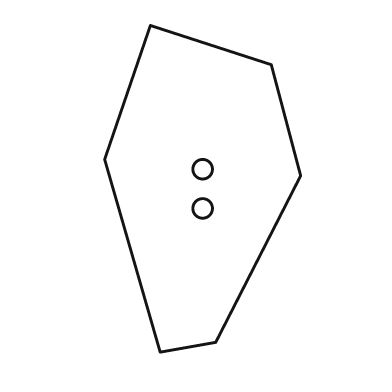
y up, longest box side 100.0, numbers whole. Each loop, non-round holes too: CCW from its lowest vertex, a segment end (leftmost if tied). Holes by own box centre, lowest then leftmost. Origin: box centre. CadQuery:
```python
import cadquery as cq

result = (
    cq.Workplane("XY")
    .moveTo(-13.0, -50.0)
    .lineTo(4.0, -47.0)
    .lineTo(30.0, 4.0)
    .lineTo(21.0, 38.0)
    .lineTo(-16.0, 50.0)
    .lineTo(-30.0, 9.0)
    .close()
    .moveTo(0.0, -6.0)
    .circle(3.0)
    .moveTo(0.0, 6.0)
    .circle(3.0)
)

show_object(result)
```